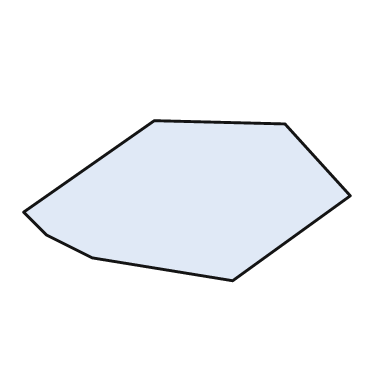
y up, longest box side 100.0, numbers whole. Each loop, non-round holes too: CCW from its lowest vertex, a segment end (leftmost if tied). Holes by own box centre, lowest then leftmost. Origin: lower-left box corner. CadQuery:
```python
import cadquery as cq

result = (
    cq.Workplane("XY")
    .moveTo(64.0, 0.0)
    .lineTo(100.0, 26.0)
    .lineTo(80.0, 48.0)
    .lineTo(40.0, 49.0)
    .lineTo(0.0, 21.0)
    .lineTo(7.0, 14.0)
    .lineTo(21.0, 7.0)
    .close()
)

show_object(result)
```